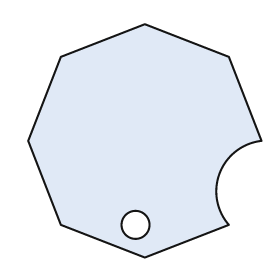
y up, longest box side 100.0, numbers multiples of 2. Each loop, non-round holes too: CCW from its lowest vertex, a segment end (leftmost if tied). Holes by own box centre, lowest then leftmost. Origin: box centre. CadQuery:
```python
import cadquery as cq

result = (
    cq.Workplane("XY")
    .moveTo(0.0, -50.0)
    .lineTo(36.0, -36.0)
    .threePointArc((32.0, -14.0), (50.0, 0.0))
    .lineTo(36.0, 36.0)
    .lineTo(0.0, 50.0)
    .lineTo(-36.0, 36.0)
    .lineTo(-50.0, 0.0)
    .lineTo(-36.0, -36.0)
    .close()
    .moveTo(-4.0, -36.0)
    .circle(6.0)
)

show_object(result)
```